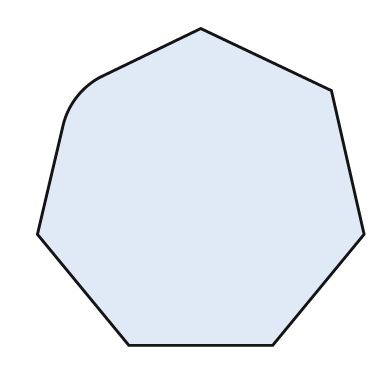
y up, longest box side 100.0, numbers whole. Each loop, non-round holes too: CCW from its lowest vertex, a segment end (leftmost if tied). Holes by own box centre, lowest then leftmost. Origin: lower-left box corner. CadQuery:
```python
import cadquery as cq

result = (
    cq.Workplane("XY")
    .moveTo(28.0, 0.0)
    .lineTo(72.0, 0.0)
    .lineTo(100.0, 34.0)
    .lineTo(90.0, 78.0)
    .lineTo(50.0, 97.0)
    .lineTo(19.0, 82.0)
    .threePointArc((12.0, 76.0), (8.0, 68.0))
    .lineTo(0.0, 34.0)
    .close()
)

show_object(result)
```